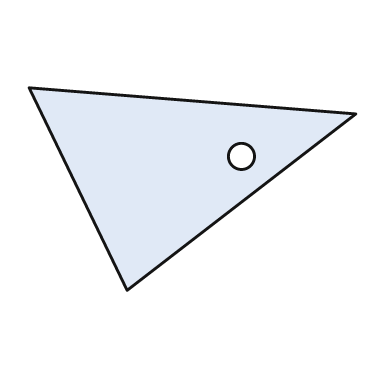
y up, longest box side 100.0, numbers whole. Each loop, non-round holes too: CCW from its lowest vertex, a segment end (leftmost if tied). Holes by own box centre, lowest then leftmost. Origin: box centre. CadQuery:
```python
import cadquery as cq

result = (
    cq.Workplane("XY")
    .moveTo(-20.0, -31.0)
    .lineTo(50.0, 23.0)
    .lineTo(-50.0, 31.0)
    .close()
    .moveTo(15.0, 10.0)
    .circle(4.0)
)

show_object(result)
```